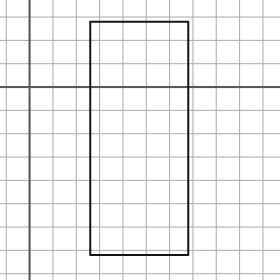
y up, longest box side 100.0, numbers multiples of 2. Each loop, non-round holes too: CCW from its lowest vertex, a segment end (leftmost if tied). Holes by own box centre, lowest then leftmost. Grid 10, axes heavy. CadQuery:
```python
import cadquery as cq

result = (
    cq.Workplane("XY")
    .moveTo(26.0, -72.0)
    .lineTo(68.0, -72.0)
    .lineTo(68.0, 28.0)
    .lineTo(26.0, 28.0)
    .close()
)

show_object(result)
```